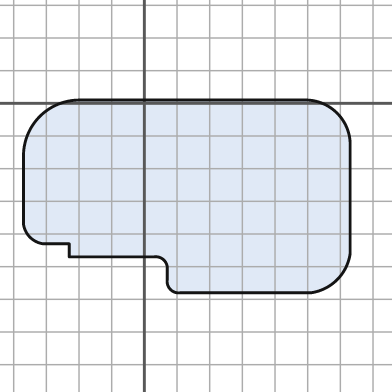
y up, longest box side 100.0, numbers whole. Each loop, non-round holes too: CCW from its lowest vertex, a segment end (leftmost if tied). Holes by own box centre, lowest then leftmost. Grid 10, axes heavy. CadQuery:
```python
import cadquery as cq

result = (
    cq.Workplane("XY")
    .moveTo(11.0, -58.0)
    .lineTo(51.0, -58.0)
    .threePointArc((59.0, -54.0), (63.0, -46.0))
    .lineTo(63.0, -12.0)
    .threePointArc((59.0, -3.0), (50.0, 1.0))
    .lineTo(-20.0, 1.0)
    .threePointArc((-32.0, -4.0), (-37.0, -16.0))
    .lineTo(-37.0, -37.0)
    .threePointArc((-35.0, -41.0), (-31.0, -43.0))
    .lineTo(-23.0, -43.0)
    .lineTo(-23.0, -47.0)
    .lineTo(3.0, -47.0)
    .threePointArc((6.0, -48.0), (7.0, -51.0))
    .lineTo(7.0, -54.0)
    .threePointArc((8.0, -57.0), (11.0, -58.0))
    .close()
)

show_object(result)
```